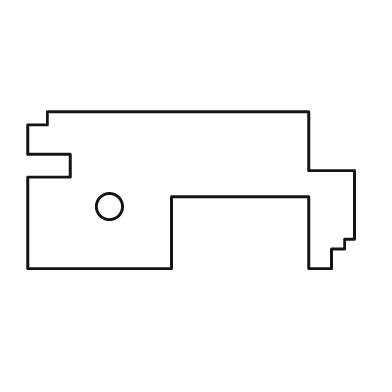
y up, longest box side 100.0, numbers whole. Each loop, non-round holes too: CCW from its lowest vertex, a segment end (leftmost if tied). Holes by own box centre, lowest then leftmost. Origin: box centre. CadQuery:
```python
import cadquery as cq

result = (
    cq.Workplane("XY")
    .moveTo(-50.0, -24.0)
    .lineTo(-6.0, -24.0)
    .lineTo(-6.0, -2.0)
    .lineTo(36.0, -2.0)
    .lineTo(36.0, -24.0)
    .lineTo(43.0, -24.0)
    .lineTo(43.0, -18.0)
    .lineTo(47.0, -18.0)
    .lineTo(47.0, -15.0)
    .lineTo(50.0, -15.0)
    .lineTo(50.0, 6.0)
    .lineTo(36.0, 6.0)
    .lineTo(36.0, 24.0)
    .lineTo(-44.0, 24.0)
    .lineTo(-44.0, 20.0)
    .lineTo(-50.0, 20.0)
    .lineTo(-50.0, 11.0)
    .lineTo(-37.0, 11.0)
    .lineTo(-37.0, 4.0)
    .lineTo(-50.0, 4.0)
    .close()
    .moveTo(-25.0, -5.0)
    .circle(4.0)
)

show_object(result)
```